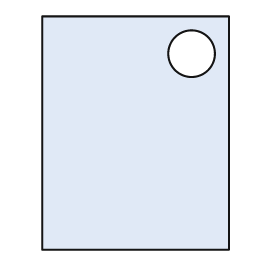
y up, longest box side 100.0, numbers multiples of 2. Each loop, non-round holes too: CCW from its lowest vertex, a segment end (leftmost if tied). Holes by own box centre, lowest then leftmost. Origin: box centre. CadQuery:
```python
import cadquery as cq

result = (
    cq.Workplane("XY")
    .moveTo(-40.0, -50.0)
    .lineTo(40.0, -50.0)
    .lineTo(40.0, 50.0)
    .lineTo(-40.0, 50.0)
    .close()
    .moveTo(24.0, 34.0)
    .circle(10.0)
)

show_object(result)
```